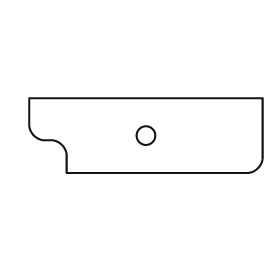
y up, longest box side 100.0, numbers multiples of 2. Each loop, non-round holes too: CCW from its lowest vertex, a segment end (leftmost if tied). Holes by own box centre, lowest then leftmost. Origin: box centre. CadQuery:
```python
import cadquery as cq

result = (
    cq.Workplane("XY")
    .moveTo(-34.0, -16.0)
    .lineTo(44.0, -16.0)
    .threePointArc((48.0, -14.0), (50.0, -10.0))
    .lineTo(50.0, 16.0)
    .lineTo(-50.0, 16.0)
    .lineTo(-50.0, 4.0)
    .threePointArc((-48.0, 0.0), (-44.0, -2.0))
    .lineTo(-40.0, -2.0)
    .threePointArc((-36.0, -4.0), (-34.0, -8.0))
    .close()
    .moveTo(0.0, 0.0)
    .circle(4.0)
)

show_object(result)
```